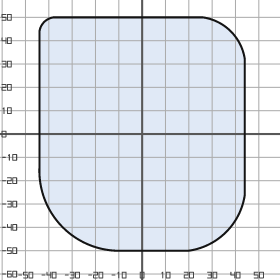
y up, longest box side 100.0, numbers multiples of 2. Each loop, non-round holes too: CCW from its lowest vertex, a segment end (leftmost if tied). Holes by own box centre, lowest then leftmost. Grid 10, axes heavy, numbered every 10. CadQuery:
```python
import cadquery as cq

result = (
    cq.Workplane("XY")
    .moveTo(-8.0, -50.0)
    .lineTo(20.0, -50.0)
    .threePointArc((36.0, -42.0), (44.0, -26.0))
    .lineTo(44.0, 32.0)
    .threePointArc((38.0, 44.0), (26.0, 50.0))
    .lineTo(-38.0, 50.0)
    .threePointArc((-42.0, 48.0), (-44.0, 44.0))
    .lineTo(-44.0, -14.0)
    .threePointArc((-34.0, -40.0), (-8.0, -50.0))
    .close()
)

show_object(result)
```